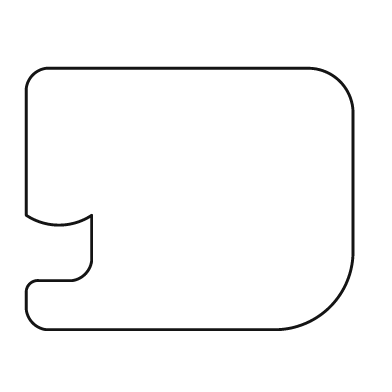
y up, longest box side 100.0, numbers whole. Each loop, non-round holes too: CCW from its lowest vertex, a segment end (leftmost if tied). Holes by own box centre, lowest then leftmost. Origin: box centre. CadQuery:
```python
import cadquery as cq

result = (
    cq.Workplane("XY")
    .moveTo(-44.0, -40.0)
    .lineTo(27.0, -40.0)
    .threePointArc((43.0, -33.0), (50.0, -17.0))
    .lineTo(50.0, 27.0)
    .threePointArc((46.0, 36.0), (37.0, 40.0))
    .lineTo(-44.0, 40.0)
    .threePointArc((-48.0, 38.0), (-50.0, 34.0))
    .lineTo(-50.0, -5.0)
    .threePointArc((-40.0, -8.0), (-30.0, -5.0))
    .lineTo(-30.0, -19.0)
    .threePointArc((-32.0, -23.0), (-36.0, -25.0))
    .lineTo(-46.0, -25.0)
    .threePointArc((-49.0, -26.0), (-50.0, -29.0))
    .lineTo(-50.0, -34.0)
    .threePointArc((-48.0, -38.0), (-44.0, -40.0))
    .close()
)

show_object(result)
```